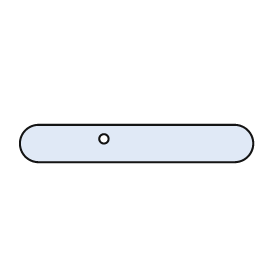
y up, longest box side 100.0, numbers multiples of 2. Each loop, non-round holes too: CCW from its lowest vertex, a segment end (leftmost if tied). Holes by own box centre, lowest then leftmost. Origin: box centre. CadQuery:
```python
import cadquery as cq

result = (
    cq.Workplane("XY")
    .moveTo(-42.0, -8.0)
    .lineTo(42.0, -8.0)
    .threePointArc((50.0, 0.0), (42.0, 8.0))
    .lineTo(-42.0, 8.0)
    .threePointArc((-50.0, 0.0), (-42.0, -8.0))
    .close()
    .moveTo(-14.0, 2.0)
    .circle(2.0)
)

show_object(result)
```